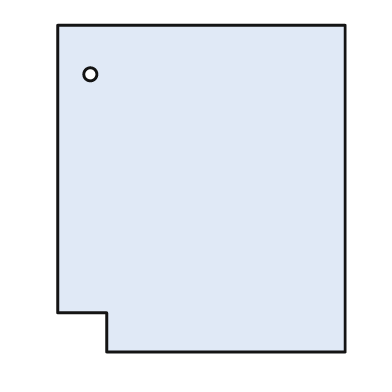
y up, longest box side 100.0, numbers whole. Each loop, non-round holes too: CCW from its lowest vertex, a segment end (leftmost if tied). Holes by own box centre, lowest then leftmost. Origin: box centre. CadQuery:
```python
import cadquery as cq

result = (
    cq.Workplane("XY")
    .moveTo(-29.0, -50.0)
    .lineTo(44.0, -50.0)
    .lineTo(44.0, 50.0)
    .lineTo(-44.0, 50.0)
    .lineTo(-44.0, -38.0)
    .lineTo(-29.0, -38.0)
    .close()
    .moveTo(-34.0, 35.0)
    .circle(2.0)
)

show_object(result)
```